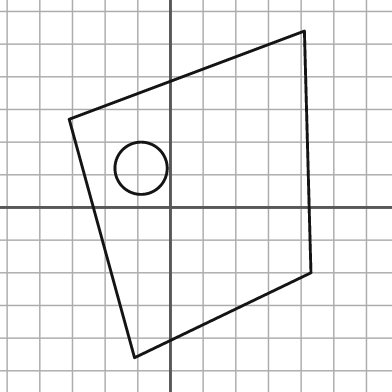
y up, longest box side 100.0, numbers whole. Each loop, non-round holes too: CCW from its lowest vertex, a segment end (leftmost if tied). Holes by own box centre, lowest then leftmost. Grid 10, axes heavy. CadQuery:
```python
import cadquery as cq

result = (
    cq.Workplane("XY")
    .moveTo(-11.0, -46.0)
    .lineTo(43.0, -20.0)
    .lineTo(41.0, 54.0)
    .lineTo(-31.0, 27.0)
    .close()
    .moveTo(-9.0, 12.0)
    .circle(8.0)
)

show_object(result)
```